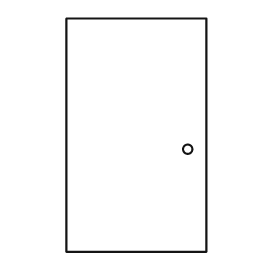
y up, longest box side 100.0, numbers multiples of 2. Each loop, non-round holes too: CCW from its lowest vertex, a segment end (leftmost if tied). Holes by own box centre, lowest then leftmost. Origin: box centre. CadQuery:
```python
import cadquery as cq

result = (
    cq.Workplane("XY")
    .moveTo(-30.0, -50.0)
    .lineTo(30.0, -50.0)
    .lineTo(30.0, 50.0)
    .lineTo(-30.0, 50.0)
    .close()
    .moveTo(22.0, -6.0)
    .circle(2.0)
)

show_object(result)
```